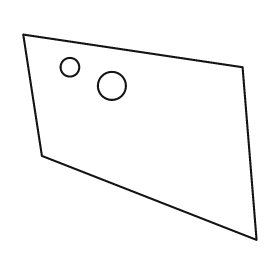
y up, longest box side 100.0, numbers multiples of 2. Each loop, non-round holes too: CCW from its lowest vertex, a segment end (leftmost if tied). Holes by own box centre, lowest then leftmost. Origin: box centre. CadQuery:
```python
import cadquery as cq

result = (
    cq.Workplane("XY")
    .moveTo(50.0, -44.0)
    .lineTo(44.0, 30.0)
    .lineTo(-50.0, 44.0)
    .lineTo(-42.0, -8.0)
    .close()
    .moveTo(-12.0, 22.0)
    .circle(6.0)
    .moveTo(-30.0, 30.0)
    .circle(4.0)
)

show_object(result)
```